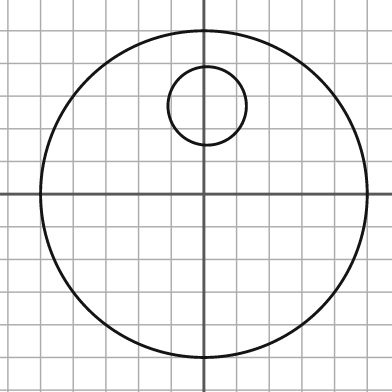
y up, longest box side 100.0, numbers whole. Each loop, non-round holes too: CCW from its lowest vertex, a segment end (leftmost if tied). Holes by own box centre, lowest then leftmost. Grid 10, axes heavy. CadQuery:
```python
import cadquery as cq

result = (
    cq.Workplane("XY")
    .moveTo(0.0, 0.0)
    .circle(50.0)
    .moveTo(1.0, 27.0)
    .circle(12.0)
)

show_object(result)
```